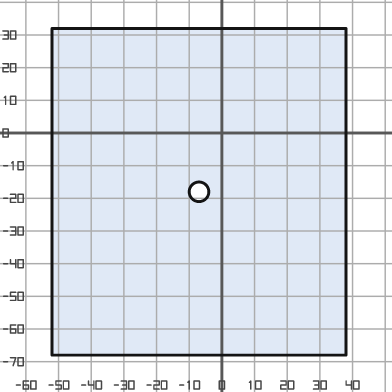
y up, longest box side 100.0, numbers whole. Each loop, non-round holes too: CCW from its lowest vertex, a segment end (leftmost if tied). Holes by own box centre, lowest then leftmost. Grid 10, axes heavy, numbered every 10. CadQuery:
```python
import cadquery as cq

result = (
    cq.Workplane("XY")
    .moveTo(-52.0, -68.0)
    .lineTo(38.0, -68.0)
    .lineTo(38.0, 32.0)
    .lineTo(-52.0, 32.0)
    .close()
    .moveTo(-7.0, -18.0)
    .circle(3.0)
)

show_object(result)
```